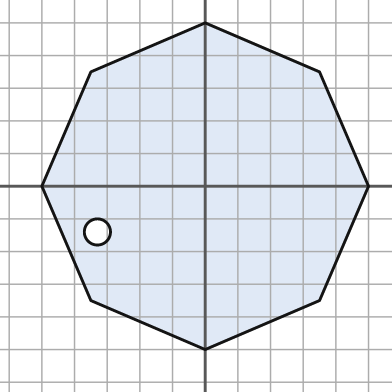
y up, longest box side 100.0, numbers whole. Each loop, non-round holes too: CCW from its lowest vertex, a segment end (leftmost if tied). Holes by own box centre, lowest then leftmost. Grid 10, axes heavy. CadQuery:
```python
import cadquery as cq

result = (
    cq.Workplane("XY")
    .moveTo(0.0, -50.0)
    .lineTo(35.0, -35.0)
    .lineTo(50.0, 0.0)
    .lineTo(35.0, 35.0)
    .lineTo(0.0, 50.0)
    .lineTo(-35.0, 35.0)
    .lineTo(-50.0, 0.0)
    .lineTo(-35.0, -35.0)
    .close()
    .moveTo(-33.0, -14.0)
    .circle(4.0)
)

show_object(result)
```